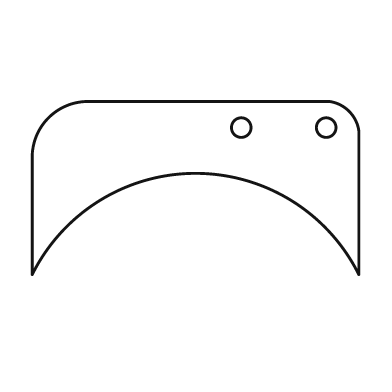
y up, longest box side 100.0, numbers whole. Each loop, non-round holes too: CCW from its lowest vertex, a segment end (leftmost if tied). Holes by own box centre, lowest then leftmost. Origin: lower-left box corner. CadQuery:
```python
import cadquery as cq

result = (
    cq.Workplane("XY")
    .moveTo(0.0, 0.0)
    .threePointArc((50.0, 31.0), (100.0, 0.0))
    .lineTo(100.0, 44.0)
    .threePointArc((97.0, 50.0), (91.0, 53.0))
    .lineTo(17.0, 53.0)
    .threePointArc((5.0, 48.0), (0.0, 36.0))
    .close()
    .moveTo(64.0, 45.0)
    .circle(3.0)
    .moveTo(90.0, 45.0)
    .circle(3.0)
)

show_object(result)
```